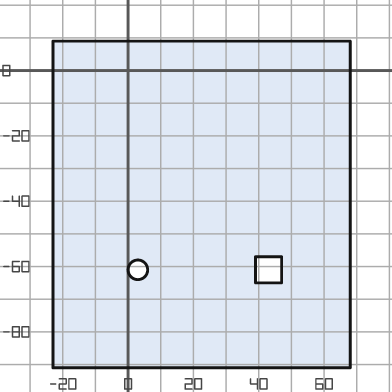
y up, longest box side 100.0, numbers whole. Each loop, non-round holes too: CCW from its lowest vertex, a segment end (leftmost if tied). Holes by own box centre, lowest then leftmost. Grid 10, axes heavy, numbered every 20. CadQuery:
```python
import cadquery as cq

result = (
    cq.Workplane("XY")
    .moveTo(-23.0, -91.0)
    .lineTo(68.0, -91.0)
    .lineTo(68.0, 9.0)
    .lineTo(-23.0, 9.0)
    .close()
    .moveTo(3.0, -61.0)
    .circle(3.0)
    .moveTo(39.0, -65.0)
    .lineTo(47.0, -65.0)
    .lineTo(47.0, -57.0)
    .lineTo(39.0, -57.0)
    .close()
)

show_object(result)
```